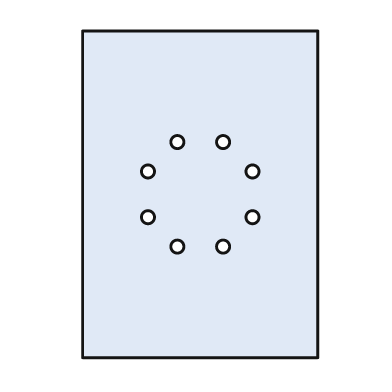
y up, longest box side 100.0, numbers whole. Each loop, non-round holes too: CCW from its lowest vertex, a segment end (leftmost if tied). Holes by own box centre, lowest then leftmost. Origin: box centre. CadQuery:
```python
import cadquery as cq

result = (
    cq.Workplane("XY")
    .moveTo(-36.0, -50.0)
    .lineTo(36.0, -50.0)
    .lineTo(36.0, 50.0)
    .lineTo(-36.0, 50.0)
    .close()
    .moveTo(-7.0, -16.0)
    .circle(2.0)
    .moveTo(7.0, -16.0)
    .circle(2.0)
    .moveTo(-16.0, -7.0)
    .circle(2.0)
    .moveTo(16.0, -7.0)
    .circle(2.0)
    .moveTo(-16.0, 7.0)
    .circle(2.0)
    .moveTo(16.0, 7.0)
    .circle(2.0)
    .moveTo(-7.0, 16.0)
    .circle(2.0)
    .moveTo(7.0, 16.0)
    .circle(2.0)
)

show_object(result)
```